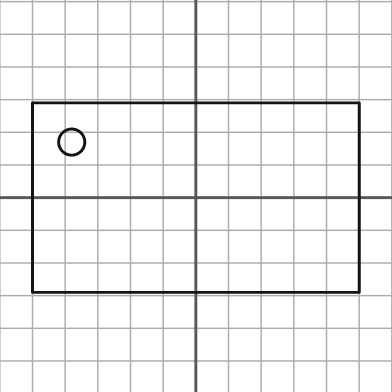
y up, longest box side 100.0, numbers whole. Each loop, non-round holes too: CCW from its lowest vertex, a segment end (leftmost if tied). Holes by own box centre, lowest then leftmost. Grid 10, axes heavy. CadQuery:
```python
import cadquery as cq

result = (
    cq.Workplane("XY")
    .moveTo(-50.0, -29.0)
    .lineTo(50.0, -29.0)
    .lineTo(50.0, 29.0)
    .lineTo(-50.0, 29.0)
    .close()
    .moveTo(-38.0, 17.0)
    .circle(4.0)
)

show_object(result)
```